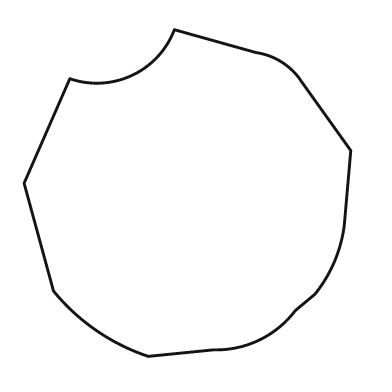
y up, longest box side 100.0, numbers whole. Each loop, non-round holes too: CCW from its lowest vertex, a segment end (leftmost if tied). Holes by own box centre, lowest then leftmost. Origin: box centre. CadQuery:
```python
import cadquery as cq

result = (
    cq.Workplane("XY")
    .moveTo(-12.0, -50.0)
    .lineTo(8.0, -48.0)
    .threePointArc((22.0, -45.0), (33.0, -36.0))
    .lineTo(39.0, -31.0)
    .threePointArc((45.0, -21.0), (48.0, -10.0))
    .lineTo(50.0, 13.0)
    .lineTo(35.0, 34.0)
    .threePointArc((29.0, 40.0), (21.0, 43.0))
    .lineTo(-4.0, 50.0)
    .threePointArc((-17.0, 36.0), (-36.0, 35.0))
    .lineTo(-50.0, 3.0)
    .lineTo(-41.0, -30.0)
    .threePointArc((-28.0, -42.0), (-12.0, -50.0))
    .close()
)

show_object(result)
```